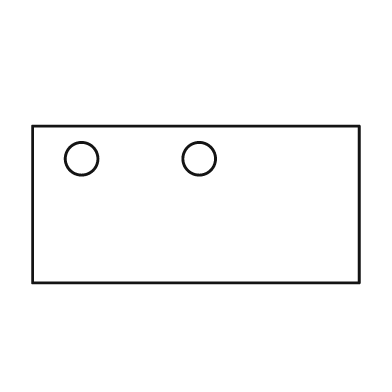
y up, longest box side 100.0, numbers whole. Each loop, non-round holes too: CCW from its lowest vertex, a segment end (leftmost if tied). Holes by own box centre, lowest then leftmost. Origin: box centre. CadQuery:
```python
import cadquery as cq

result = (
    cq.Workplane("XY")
    .moveTo(-50.0, -24.0)
    .lineTo(50.0, -24.0)
    .lineTo(50.0, 24.0)
    .lineTo(-50.0, 24.0)
    .close()
    .moveTo(-35.0, 14.0)
    .circle(5.0)
    .moveTo(1.0, 14.0)
    .circle(5.0)
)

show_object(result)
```